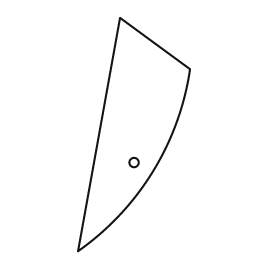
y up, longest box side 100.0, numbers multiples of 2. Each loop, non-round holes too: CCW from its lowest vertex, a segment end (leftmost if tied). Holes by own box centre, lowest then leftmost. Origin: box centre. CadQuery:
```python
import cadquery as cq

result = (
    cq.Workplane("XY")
    .moveTo(-24.0, -50.0)
    .threePointArc((8.0, -16.0), (24.0, 28.0))
    .lineTo(-6.0, 50.0)
    .close()
    .moveTo(0.0, -12.0)
    .circle(2.0)
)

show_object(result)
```